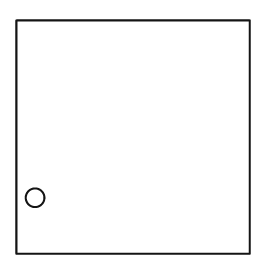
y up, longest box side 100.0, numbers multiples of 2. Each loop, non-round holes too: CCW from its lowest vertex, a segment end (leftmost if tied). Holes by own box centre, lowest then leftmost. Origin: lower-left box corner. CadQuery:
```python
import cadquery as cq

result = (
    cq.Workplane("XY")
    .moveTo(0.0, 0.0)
    .lineTo(100.0, 0.0)
    .lineTo(100.0, 100.0)
    .lineTo(0.0, 100.0)
    .close()
    .moveTo(8.0, 24.0)
    .circle(4.0)
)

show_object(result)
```